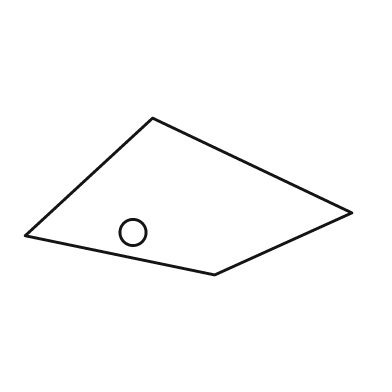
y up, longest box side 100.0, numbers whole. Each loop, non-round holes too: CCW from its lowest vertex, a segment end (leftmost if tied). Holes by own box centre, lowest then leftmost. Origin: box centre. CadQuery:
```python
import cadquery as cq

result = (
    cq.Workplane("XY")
    .moveTo(8.0, -24.0)
    .lineTo(50.0, -5.0)
    .lineTo(-11.0, 24.0)
    .lineTo(-50.0, -12.0)
    .close()
    .moveTo(-17.0, -11.0)
    .circle(4.0)
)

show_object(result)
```